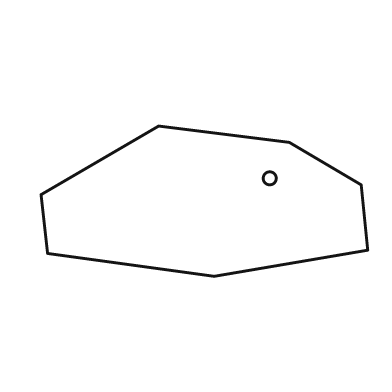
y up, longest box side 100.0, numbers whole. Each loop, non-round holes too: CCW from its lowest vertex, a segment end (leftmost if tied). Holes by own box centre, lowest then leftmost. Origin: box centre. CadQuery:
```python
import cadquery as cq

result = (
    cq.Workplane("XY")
    .moveTo(3.0, -23.0)
    .lineTo(50.0, -15.0)
    .lineTo(48.0, 5.0)
    .lineTo(26.0, 18.0)
    .lineTo(-14.0, 23.0)
    .lineTo(-50.0, 2.0)
    .lineTo(-48.0, -16.0)
    .close()
    .moveTo(20.0, 7.0)
    .circle(2.0)
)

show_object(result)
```